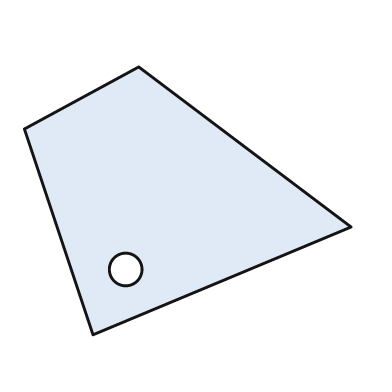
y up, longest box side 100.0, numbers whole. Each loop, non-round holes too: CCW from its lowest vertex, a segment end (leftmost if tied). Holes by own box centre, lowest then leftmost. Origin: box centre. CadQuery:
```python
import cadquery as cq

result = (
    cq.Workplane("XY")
    .moveTo(-29.0, -41.0)
    .lineTo(50.0, -8.0)
    .lineTo(-15.0, 41.0)
    .lineTo(-50.0, 22.0)
    .close()
    .moveTo(-19.0, -21.0)
    .circle(5.0)
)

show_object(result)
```